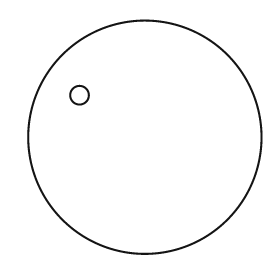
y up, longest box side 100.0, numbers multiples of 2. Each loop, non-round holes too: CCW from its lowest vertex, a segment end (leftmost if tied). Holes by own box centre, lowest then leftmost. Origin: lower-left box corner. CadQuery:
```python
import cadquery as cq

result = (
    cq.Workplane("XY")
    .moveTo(50.0, 50.0)
    .circle(50.0)
    .moveTo(22.0, 68.0)
    .circle(4.0)
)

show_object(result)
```